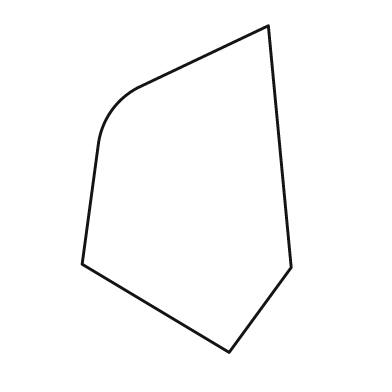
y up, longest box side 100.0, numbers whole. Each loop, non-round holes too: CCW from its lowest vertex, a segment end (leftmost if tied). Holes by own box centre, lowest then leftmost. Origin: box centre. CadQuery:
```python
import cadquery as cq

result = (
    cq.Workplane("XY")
    .moveTo(13.0, -50.0)
    .lineTo(32.0, -24.0)
    .lineTo(25.0, 50.0)
    .lineTo(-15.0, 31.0)
    .threePointArc((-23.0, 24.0), (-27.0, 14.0))
    .lineTo(-32.0, -23.0)
    .close()
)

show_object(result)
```